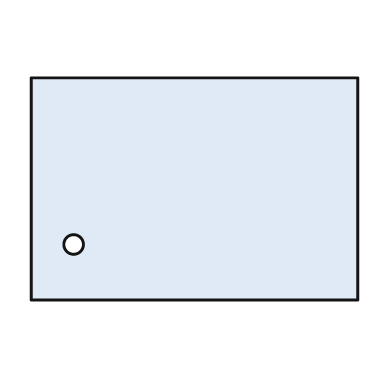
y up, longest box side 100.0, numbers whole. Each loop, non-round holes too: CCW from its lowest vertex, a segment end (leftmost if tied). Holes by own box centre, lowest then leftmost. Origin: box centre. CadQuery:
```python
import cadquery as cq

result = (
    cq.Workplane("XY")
    .moveTo(-50.0, -34.0)
    .lineTo(50.0, -34.0)
    .lineTo(50.0, 34.0)
    .lineTo(-50.0, 34.0)
    .close()
    .moveTo(-37.0, -17.0)
    .circle(3.0)
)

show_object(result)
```